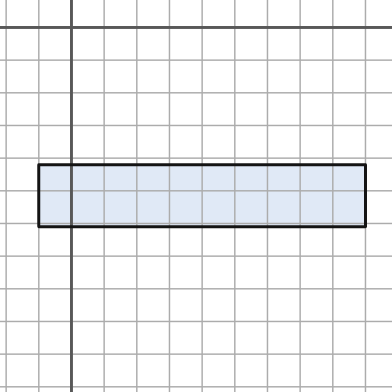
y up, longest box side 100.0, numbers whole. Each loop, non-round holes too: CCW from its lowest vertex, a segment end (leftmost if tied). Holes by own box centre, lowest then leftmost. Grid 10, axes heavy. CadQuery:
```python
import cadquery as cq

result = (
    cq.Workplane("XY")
    .moveTo(-10.0, -61.0)
    .lineTo(90.0, -61.0)
    .lineTo(90.0, -42.0)
    .lineTo(-10.0, -42.0)
    .close()
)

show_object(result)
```